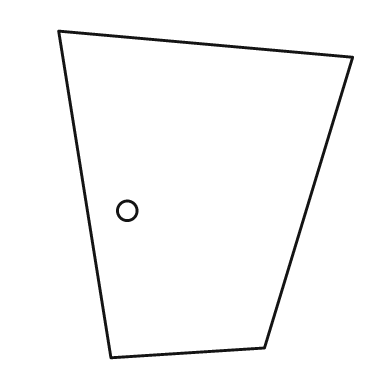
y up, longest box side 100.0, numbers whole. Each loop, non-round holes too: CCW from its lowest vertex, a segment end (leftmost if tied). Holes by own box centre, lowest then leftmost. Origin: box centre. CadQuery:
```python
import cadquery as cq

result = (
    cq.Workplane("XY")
    .moveTo(-29.0, -50.0)
    .lineTo(18.0, -47.0)
    .lineTo(45.0, 42.0)
    .lineTo(-45.0, 50.0)
    .close()
    .moveTo(-24.0, -5.0)
    .circle(3.0)
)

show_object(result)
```